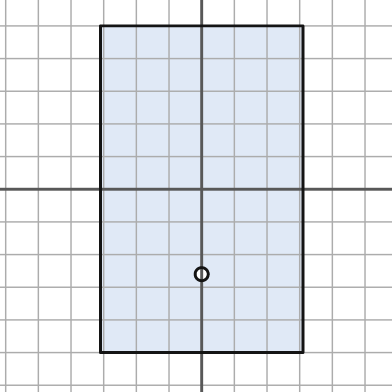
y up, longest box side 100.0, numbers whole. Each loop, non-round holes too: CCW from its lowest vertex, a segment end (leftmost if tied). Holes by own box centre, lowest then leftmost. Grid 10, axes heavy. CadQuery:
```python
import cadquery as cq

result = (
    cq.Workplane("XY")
    .moveTo(-31.0, -50.0)
    .lineTo(31.0, -50.0)
    .lineTo(31.0, 50.0)
    .lineTo(-31.0, 50.0)
    .close()
    .moveTo(0.0, -26.0)
    .circle(2.0)
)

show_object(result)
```